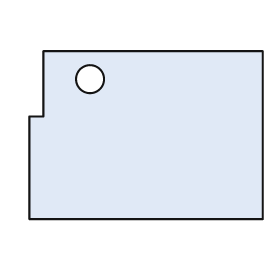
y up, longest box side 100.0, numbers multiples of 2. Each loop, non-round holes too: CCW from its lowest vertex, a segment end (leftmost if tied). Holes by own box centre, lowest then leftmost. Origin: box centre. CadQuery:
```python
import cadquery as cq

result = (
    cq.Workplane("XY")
    .moveTo(-50.0, -36.0)
    .lineTo(50.0, -36.0)
    .lineTo(50.0, 36.0)
    .lineTo(-44.0, 36.0)
    .lineTo(-44.0, 8.0)
    .lineTo(-50.0, 8.0)
    .close()
    .moveTo(-24.0, 24.0)
    .circle(6.0)
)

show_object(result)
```